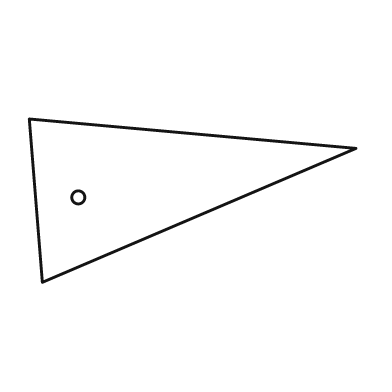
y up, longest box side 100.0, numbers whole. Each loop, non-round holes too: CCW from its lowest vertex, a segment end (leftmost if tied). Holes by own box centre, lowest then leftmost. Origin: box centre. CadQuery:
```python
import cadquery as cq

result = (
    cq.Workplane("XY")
    .moveTo(-46.0, -25.0)
    .lineTo(50.0, 16.0)
    .lineTo(-50.0, 25.0)
    .close()
    .moveTo(-35.0, 1.0)
    .circle(2.0)
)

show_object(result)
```